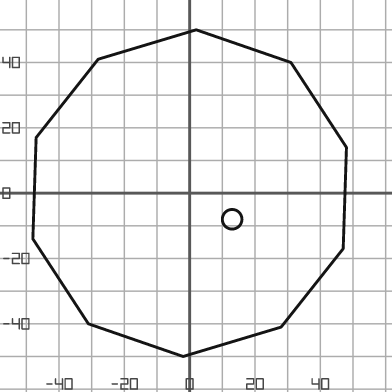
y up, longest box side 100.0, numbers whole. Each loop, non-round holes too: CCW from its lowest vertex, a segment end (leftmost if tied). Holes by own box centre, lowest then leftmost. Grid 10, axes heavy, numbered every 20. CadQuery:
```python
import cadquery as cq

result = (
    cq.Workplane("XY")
    .moveTo(-2.0, -50.0)
    .lineTo(28.0, -41.0)
    .lineTo(47.0, -17.0)
    .lineTo(48.0, 14.0)
    .lineTo(31.0, 40.0)
    .lineTo(2.0, 50.0)
    .lineTo(-28.0, 41.0)
    .lineTo(-47.0, 17.0)
    .lineTo(-48.0, -14.0)
    .lineTo(-31.0, -40.0)
    .close()
    .moveTo(13.0, -8.0)
    .circle(3.0)
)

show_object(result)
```